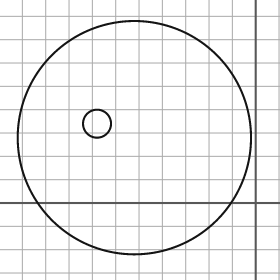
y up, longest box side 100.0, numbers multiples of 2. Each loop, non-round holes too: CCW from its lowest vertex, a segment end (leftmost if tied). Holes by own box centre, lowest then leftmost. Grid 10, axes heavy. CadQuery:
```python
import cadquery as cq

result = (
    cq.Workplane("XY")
    .moveTo(-52.0, 28.0)
    .circle(50.0)
    .moveTo(-68.0, 34.0)
    .circle(6.0)
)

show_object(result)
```